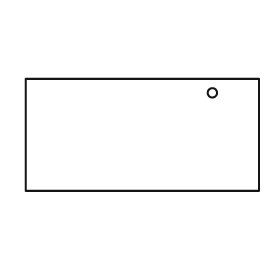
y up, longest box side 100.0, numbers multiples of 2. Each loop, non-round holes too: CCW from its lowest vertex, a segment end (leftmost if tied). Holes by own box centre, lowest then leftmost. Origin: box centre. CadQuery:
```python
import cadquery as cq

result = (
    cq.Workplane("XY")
    .moveTo(-50.0, -24.0)
    .lineTo(50.0, -24.0)
    .lineTo(50.0, 24.0)
    .lineTo(-50.0, 24.0)
    .close()
    .moveTo(30.0, 18.0)
    .circle(2.0)
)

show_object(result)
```